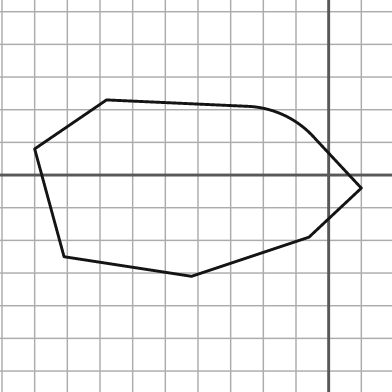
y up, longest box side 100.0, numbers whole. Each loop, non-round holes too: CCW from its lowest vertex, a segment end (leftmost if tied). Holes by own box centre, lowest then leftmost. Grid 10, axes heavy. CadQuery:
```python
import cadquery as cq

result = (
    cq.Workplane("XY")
    .moveTo(-42.0, -31.0)
    .lineTo(-6.0, -19.0)
    .lineTo(10.0, -4.0)
    .lineTo(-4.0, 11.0)
    .threePointArc((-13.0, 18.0), (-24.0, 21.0))
    .lineTo(-68.0, 23.0)
    .lineTo(-90.0, 8.0)
    .lineTo(-81.0, -25.0)
    .close()
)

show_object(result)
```